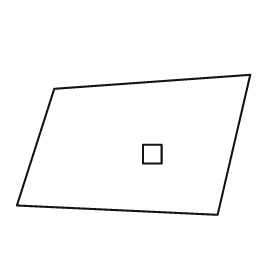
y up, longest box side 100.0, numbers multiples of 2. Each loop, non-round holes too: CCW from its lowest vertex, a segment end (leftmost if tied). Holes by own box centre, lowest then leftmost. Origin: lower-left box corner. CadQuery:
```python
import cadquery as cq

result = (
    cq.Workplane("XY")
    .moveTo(86.0, 0.0)
    .lineTo(100.0, 60.0)
    .lineTo(16.0, 54.0)
    .lineTo(0.0, 4.0)
    .close()
    .moveTo(54.0, 22.0)
    .lineTo(62.0, 22.0)
    .lineTo(62.0, 30.0)
    .lineTo(54.0, 30.0)
    .close()
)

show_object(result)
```